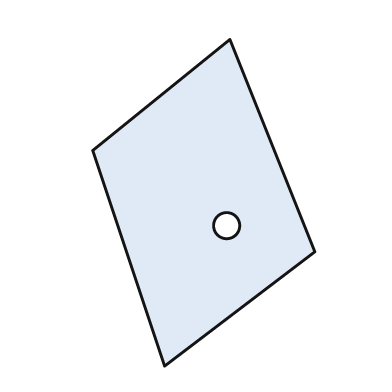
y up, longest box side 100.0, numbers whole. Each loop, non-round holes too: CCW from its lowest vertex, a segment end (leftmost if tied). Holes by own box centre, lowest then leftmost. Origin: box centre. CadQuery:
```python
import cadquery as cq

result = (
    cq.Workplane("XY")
    .moveTo(-12.0, -50.0)
    .lineTo(34.0, -15.0)
    .lineTo(8.0, 50.0)
    .lineTo(-34.0, 16.0)
    .close()
    .moveTo(7.0, -7.0)
    .circle(4.0)
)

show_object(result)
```